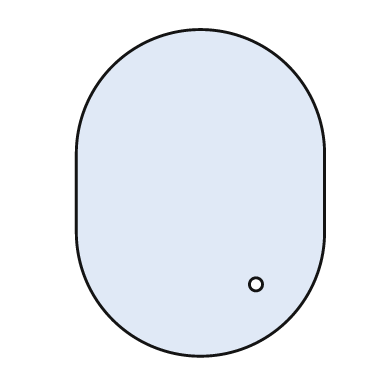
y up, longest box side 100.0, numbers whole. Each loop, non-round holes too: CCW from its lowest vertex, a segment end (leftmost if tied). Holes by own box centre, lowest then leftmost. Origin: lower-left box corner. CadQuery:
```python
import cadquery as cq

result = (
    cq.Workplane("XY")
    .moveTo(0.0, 38.0)
    .threePointArc((38.0, 0.0), (76.0, 38.0))
    .lineTo(76.0, 62.0)
    .threePointArc((38.0, 100.0), (0.0, 62.0))
    .close()
    .moveTo(55.0, 22.0)
    .circle(2.0)
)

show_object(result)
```